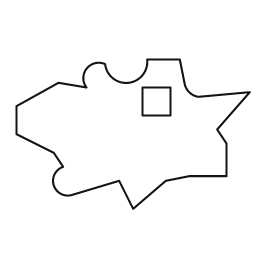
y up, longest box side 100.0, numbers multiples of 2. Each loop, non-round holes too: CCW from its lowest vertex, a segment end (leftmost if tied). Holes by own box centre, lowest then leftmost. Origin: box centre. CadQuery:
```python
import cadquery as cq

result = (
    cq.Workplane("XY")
    .moveTo(0.0, -32.0)
    .lineTo(14.0, -20.0)
    .lineTo(24.0, -18.0)
    .lineTo(40.0, -18.0)
    .lineTo(40.0, -4.0)
    .lineTo(36.0, 2.0)
    .lineTo(50.0, 18.0)
    .lineTo(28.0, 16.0)
    .threePointArc((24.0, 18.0), (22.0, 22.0))
    .lineTo(20.0, 32.0)
    .lineTo(6.0, 32.0)
    .threePointArc((-2.0, 22.0), (-12.0, 30.0))
    .threePointArc((-20.0, 28.0), (-20.0, 20.0))
    .lineTo(-32.0, 22.0)
    .lineTo(-50.0, 12.0)
    .lineTo(-50.0, 0.0)
    .lineTo(-34.0, -8.0)
    .lineTo(-30.0, -14.0)
    .threePointArc((-34.0, -22.0), (-26.0, -26.0))
    .lineTo(-6.0, -20.0)
    .close()
    .moveTo(4.0, 8.0)
    .lineTo(16.0, 8.0)
    .lineTo(16.0, 20.0)
    .lineTo(4.0, 20.0)
    .close()
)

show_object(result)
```